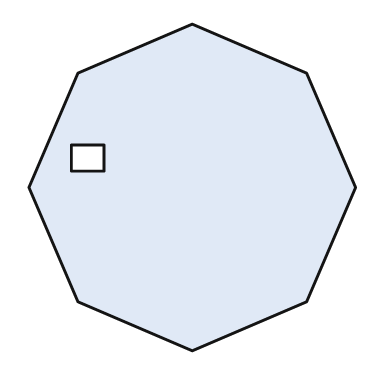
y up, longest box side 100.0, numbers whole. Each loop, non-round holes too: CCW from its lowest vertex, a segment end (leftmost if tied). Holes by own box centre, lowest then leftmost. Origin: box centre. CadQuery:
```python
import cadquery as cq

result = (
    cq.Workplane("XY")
    .moveTo(0.0, -50.0)
    .lineTo(35.0, -35.0)
    .lineTo(50.0, 0.0)
    .lineTo(35.0, 35.0)
    .lineTo(0.0, 50.0)
    .lineTo(-35.0, 35.0)
    .lineTo(-50.0, 0.0)
    .lineTo(-35.0, -35.0)
    .close()
    .moveTo(-37.0, 5.0)
    .lineTo(-27.0, 5.0)
    .lineTo(-27.0, 13.0)
    .lineTo(-37.0, 13.0)
    .close()
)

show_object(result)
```